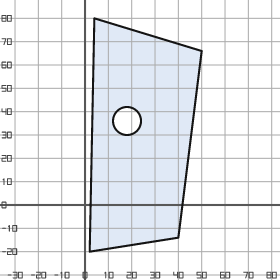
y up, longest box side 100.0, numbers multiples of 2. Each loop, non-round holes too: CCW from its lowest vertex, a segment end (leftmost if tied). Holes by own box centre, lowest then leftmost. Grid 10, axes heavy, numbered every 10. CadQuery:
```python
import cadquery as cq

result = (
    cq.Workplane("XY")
    .moveTo(2.0, -20.0)
    .lineTo(40.0, -14.0)
    .lineTo(50.0, 66.0)
    .lineTo(4.0, 80.0)
    .close()
    .moveTo(18.0, 36.0)
    .circle(6.0)
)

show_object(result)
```